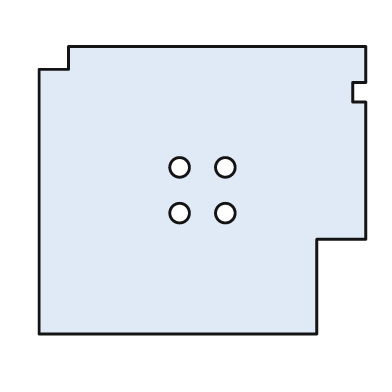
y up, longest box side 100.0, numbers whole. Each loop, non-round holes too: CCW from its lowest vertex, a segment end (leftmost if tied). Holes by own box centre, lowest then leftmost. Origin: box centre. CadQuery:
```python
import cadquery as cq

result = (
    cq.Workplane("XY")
    .moveTo(-50.0, -44.0)
    .lineTo(35.0, -44.0)
    .lineTo(35.0, -15.0)
    .lineTo(50.0, -15.0)
    .lineTo(50.0, 27.0)
    .lineTo(46.0, 27.0)
    .lineTo(46.0, 33.0)
    .lineTo(50.0, 33.0)
    .lineTo(50.0, 44.0)
    .lineTo(-41.0, 44.0)
    .lineTo(-41.0, 37.0)
    .lineTo(-50.0, 37.0)
    .close()
    .moveTo(-7.0, -7.0)
    .circle(3.0)
    .moveTo(7.0, -7.0)
    .circle(3.0)
    .moveTo(-7.0, 7.0)
    .circle(3.0)
    .moveTo(7.0, 7.0)
    .circle(3.0)
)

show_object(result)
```